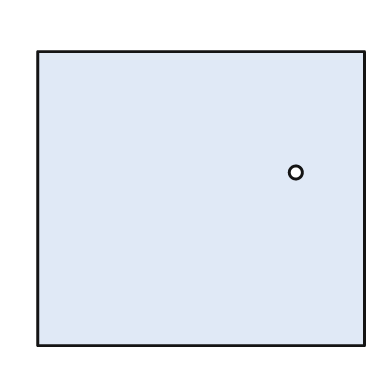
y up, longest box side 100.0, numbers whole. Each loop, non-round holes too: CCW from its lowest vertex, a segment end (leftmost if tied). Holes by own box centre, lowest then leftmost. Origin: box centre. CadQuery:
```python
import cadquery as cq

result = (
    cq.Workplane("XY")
    .moveTo(-50.0, -45.0)
    .lineTo(50.0, -45.0)
    .lineTo(50.0, 45.0)
    .lineTo(-50.0, 45.0)
    .close()
    .moveTo(29.0, 8.0)
    .circle(2.0)
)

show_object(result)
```